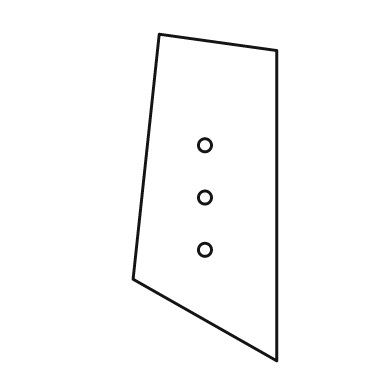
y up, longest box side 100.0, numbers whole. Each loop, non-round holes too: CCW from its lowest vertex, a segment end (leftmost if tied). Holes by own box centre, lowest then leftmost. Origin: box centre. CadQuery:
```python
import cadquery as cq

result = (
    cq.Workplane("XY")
    .moveTo(22.0, -50.0)
    .lineTo(22.0, 45.0)
    .lineTo(-14.0, 50.0)
    .lineTo(-22.0, -25.0)
    .close()
    .moveTo(0.0, -16.0)
    .circle(2.0)
    .moveTo(0.0, 0.0)
    .circle(2.0)
    .moveTo(0.0, 16.0)
    .circle(2.0)
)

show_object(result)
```